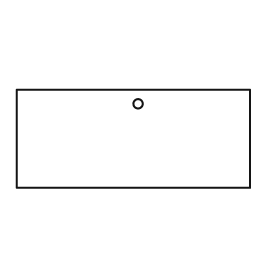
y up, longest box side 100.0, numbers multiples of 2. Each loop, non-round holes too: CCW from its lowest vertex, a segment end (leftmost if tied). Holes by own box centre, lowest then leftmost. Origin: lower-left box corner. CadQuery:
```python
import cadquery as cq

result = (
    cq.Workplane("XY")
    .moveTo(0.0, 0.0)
    .lineTo(100.0, 0.0)
    .lineTo(100.0, 42.0)
    .lineTo(0.0, 42.0)
    .close()
    .moveTo(52.0, 36.0)
    .circle(2.0)
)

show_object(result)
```